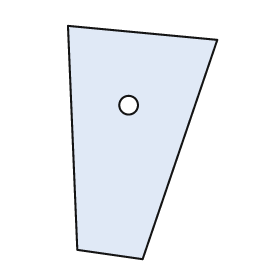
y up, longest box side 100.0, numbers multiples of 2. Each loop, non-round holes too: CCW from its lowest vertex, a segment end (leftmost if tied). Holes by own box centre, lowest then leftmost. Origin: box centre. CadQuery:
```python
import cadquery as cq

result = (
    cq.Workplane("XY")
    .moveTo(0.0, -50.0)
    .lineTo(32.0, 44.0)
    .lineTo(-32.0, 50.0)
    .lineTo(-28.0, -46.0)
    .close()
    .moveTo(-6.0, 16.0)
    .circle(4.0)
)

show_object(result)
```